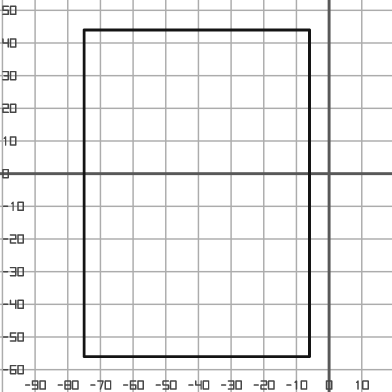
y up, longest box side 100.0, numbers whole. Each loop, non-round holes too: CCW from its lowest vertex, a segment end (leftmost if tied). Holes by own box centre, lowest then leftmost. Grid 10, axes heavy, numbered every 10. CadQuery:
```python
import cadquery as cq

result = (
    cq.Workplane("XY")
    .moveTo(-75.0, -56.0)
    .lineTo(-6.0, -56.0)
    .lineTo(-6.0, 44.0)
    .lineTo(-75.0, 44.0)
    .close()
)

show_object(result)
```